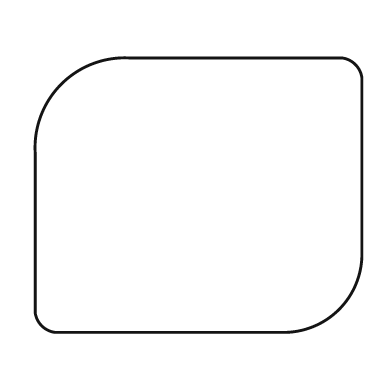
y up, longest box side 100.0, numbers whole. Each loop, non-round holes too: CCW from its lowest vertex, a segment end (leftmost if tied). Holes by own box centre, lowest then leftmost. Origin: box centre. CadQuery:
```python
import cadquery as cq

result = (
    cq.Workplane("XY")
    .moveTo(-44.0, -42.0)
    .lineTo(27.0, -42.0)
    .threePointArc((43.0, -35.0), (50.0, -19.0))
    .lineTo(50.0, 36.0)
    .threePointArc((48.0, 40.0), (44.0, 42.0))
    .lineTo(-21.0, 42.0)
    .threePointArc((-42.0, 34.0), (-50.0, 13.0))
    .lineTo(-50.0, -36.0)
    .threePointArc((-48.0, -40.0), (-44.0, -42.0))
    .close()
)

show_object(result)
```